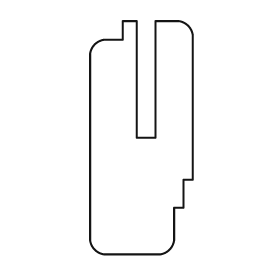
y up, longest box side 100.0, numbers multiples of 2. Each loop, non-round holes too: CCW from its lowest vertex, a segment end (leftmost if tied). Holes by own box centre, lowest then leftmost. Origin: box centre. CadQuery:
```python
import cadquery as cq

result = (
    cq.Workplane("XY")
    .moveTo(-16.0, -50.0)
    .lineTo(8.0, -50.0)
    .threePointArc((12.0, -48.0), (14.0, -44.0))
    .lineTo(14.0, -30.0)
    .lineTo(18.0, -30.0)
    .lineTo(18.0, -18.0)
    .lineTo(22.0, -18.0)
    .lineTo(22.0, 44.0)
    .threePointArc((20.0, 48.0), (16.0, 50.0))
    .lineTo(6.0, 50.0)
    .lineTo(6.0, 0.0)
    .lineTo(-2.0, 0.0)
    .lineTo(-2.0, 50.0)
    .lineTo(-8.0, 50.0)
    .lineTo(-8.0, 42.0)
    .lineTo(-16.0, 42.0)
    .threePointArc((-20.0, 40.0), (-22.0, 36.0))
    .lineTo(-22.0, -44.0)
    .threePointArc((-20.0, -48.0), (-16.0, -50.0))
    .close()
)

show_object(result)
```